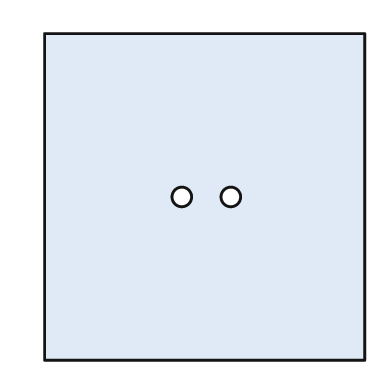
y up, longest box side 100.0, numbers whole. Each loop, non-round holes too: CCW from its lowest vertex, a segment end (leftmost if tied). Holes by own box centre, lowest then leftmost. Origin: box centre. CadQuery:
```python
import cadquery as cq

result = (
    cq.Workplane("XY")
    .moveTo(-49.0, -50.0)
    .lineTo(49.0, -50.0)
    .lineTo(49.0, 50.0)
    .lineTo(-49.0, 50.0)
    .close()
    .moveTo(-7.0, 0.0)
    .circle(3.0)
    .moveTo(8.0, 0.0)
    .circle(3.0)
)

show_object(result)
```